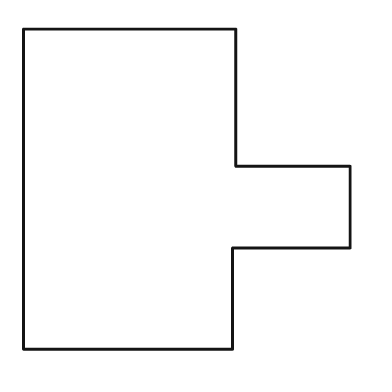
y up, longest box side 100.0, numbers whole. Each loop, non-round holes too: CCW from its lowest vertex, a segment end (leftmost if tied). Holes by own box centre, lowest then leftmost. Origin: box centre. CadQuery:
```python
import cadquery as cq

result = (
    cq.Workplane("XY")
    .moveTo(-50.0, -49.0)
    .lineTo(14.0, -49.0)
    .lineTo(14.0, -18.0)
    .lineTo(50.0, -18.0)
    .lineTo(50.0, 7.0)
    .lineTo(15.0, 7.0)
    .lineTo(15.0, 49.0)
    .lineTo(-50.0, 49.0)
    .close()
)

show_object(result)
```